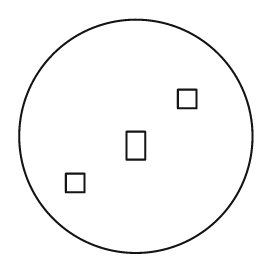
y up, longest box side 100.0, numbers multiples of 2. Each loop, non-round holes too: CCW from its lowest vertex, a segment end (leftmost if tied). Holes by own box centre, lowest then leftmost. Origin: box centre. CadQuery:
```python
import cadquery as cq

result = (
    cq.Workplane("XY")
    .moveTo(0.0, 0.0)
    .circle(50.0)
    .moveTo(-30.0, -24.0)
    .lineTo(-22.0, -24.0)
    .lineTo(-22.0, -16.0)
    .lineTo(-30.0, -16.0)
    .close()
    .moveTo(-4.0, -10.0)
    .lineTo(4.0, -10.0)
    .lineTo(4.0, 2.0)
    .lineTo(-4.0, 2.0)
    .close()
    .moveTo(18.0, 12.0)
    .lineTo(26.0, 12.0)
    .lineTo(26.0, 20.0)
    .lineTo(18.0, 20.0)
    .close()
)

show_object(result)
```